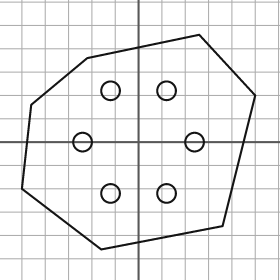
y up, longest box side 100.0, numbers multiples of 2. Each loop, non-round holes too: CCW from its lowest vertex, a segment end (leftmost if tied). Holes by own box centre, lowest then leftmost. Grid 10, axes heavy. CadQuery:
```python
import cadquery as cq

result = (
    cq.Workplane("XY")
    .moveTo(-16.0, -46.0)
    .lineTo(36.0, -36.0)
    .lineTo(50.0, 20.0)
    .lineTo(26.0, 46.0)
    .lineTo(-22.0, 36.0)
    .lineTo(-46.0, 16.0)
    .lineTo(-50.0, -20.0)
    .close()
    .moveTo(-12.0, -22.0)
    .circle(4.0)
    .moveTo(12.0, -22.0)
    .circle(4.0)
    .moveTo(-24.0, 0.0)
    .circle(4.0)
    .moveTo(24.0, 0.0)
    .circle(4.0)
    .moveTo(-12.0, 22.0)
    .circle(4.0)
    .moveTo(12.0, 22.0)
    .circle(4.0)
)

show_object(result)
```